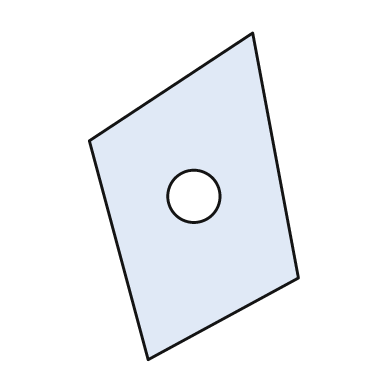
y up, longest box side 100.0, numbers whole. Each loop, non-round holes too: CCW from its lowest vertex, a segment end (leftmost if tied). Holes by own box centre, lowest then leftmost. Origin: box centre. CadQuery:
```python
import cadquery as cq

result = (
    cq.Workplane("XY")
    .moveTo(-14.0, -50.0)
    .lineTo(32.0, -25.0)
    .lineTo(18.0, 50.0)
    .lineTo(-32.0, 17.0)
    .close()
    .moveTo(0.0, 0.0)
    .circle(8.0)
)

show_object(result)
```